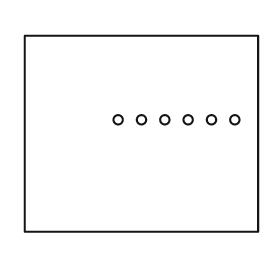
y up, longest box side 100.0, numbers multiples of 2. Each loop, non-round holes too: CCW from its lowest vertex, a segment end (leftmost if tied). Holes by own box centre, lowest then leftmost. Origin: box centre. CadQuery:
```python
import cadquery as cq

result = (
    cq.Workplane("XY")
    .moveTo(-50.0, -42.0)
    .lineTo(50.0, -42.0)
    .lineTo(50.0, 42.0)
    .lineTo(-50.0, 42.0)
    .close()
    .moveTo(-10.0, 6.0)
    .circle(2.0)
    .moveTo(0.0, 6.0)
    .circle(2.0)
    .moveTo(10.0, 6.0)
    .circle(2.0)
    .moveTo(20.0, 6.0)
    .circle(2.0)
    .moveTo(30.0, 6.0)
    .circle(2.0)
    .moveTo(40.0, 6.0)
    .circle(2.0)
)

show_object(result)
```